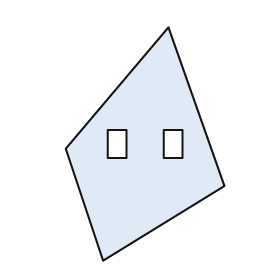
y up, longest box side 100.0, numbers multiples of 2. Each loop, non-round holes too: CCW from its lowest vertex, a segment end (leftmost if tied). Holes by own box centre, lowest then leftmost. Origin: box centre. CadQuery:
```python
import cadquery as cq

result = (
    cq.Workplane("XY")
    .moveTo(-18.0, -50.0)
    .lineTo(34.0, -18.0)
    .lineTo(10.0, 50.0)
    .lineTo(-34.0, -2.0)
    .close()
    .moveTo(-16.0, -6.0)
    .lineTo(-8.0, -6.0)
    .lineTo(-8.0, 6.0)
    .lineTo(-16.0, 6.0)
    .close()
    .moveTo(8.0, -6.0)
    .lineTo(16.0, -6.0)
    .lineTo(16.0, 6.0)
    .lineTo(8.0, 6.0)
    .close()
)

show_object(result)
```